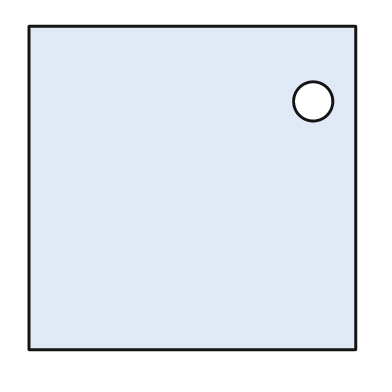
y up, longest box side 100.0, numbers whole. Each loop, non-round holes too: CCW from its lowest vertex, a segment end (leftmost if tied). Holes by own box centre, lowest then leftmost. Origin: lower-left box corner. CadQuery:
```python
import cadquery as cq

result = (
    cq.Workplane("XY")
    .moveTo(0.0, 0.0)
    .lineTo(100.0, 0.0)
    .lineTo(100.0, 99.0)
    .lineTo(0.0, 99.0)
    .close()
    .moveTo(87.0, 76.0)
    .circle(6.0)
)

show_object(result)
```